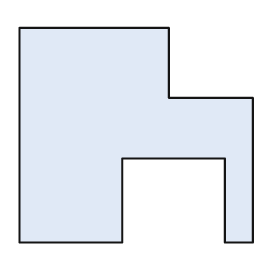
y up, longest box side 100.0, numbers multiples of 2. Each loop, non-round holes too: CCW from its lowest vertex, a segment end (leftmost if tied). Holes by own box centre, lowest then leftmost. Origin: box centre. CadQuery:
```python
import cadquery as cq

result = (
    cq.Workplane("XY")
    .moveTo(-50.0, -46.0)
    .lineTo(-6.0, -46.0)
    .lineTo(-6.0, -10.0)
    .lineTo(38.0, -10.0)
    .lineTo(38.0, -46.0)
    .lineTo(50.0, -46.0)
    .lineTo(50.0, 16.0)
    .lineTo(14.0, 16.0)
    .lineTo(14.0, 46.0)
    .lineTo(-50.0, 46.0)
    .close()
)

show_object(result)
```